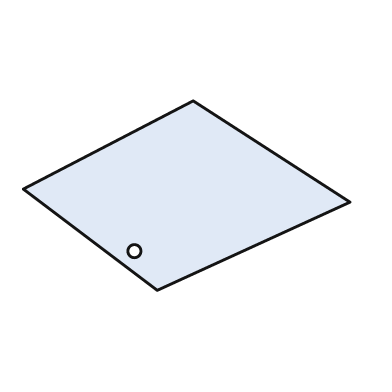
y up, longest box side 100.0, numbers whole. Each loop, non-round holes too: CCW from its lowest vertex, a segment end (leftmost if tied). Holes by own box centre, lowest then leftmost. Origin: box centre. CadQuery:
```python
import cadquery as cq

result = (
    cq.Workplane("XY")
    .moveTo(-9.0, -29.0)
    .lineTo(50.0, -2.0)
    .lineTo(2.0, 29.0)
    .lineTo(-50.0, 2.0)
    .close()
    .moveTo(-16.0, -17.0)
    .circle(2.0)
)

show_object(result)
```